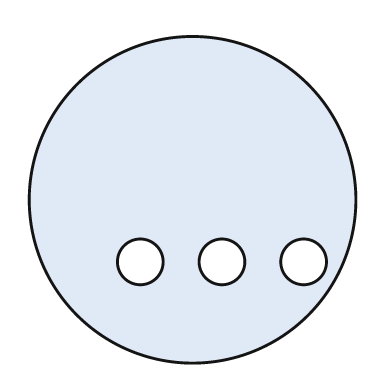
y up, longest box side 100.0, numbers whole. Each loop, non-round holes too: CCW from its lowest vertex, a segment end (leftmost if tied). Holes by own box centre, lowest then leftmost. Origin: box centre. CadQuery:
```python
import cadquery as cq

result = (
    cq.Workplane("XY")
    .moveTo(0.0, 0.0)
    .circle(50.0)
    .moveTo(-16.0, -19.0)
    .circle(7.0)
    .moveTo(9.0, -19.0)
    .circle(7.0)
    .moveTo(34.0, -19.0)
    .circle(7.0)
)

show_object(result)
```